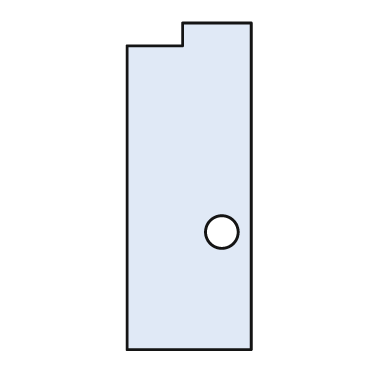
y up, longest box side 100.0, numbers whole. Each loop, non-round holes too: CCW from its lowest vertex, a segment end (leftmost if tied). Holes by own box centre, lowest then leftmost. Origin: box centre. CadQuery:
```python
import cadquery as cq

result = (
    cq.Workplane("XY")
    .moveTo(-19.0, -50.0)
    .lineTo(19.0, -50.0)
    .lineTo(19.0, 50.0)
    .lineTo(-2.0, 50.0)
    .lineTo(-2.0, 43.0)
    .lineTo(-19.0, 43.0)
    .close()
    .moveTo(10.0, -14.0)
    .circle(5.0)
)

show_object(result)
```